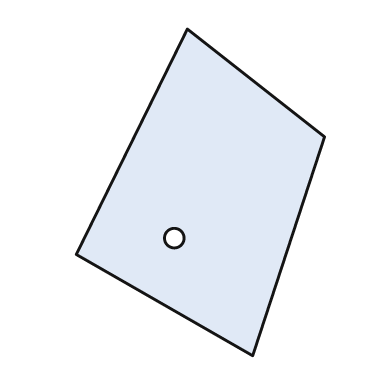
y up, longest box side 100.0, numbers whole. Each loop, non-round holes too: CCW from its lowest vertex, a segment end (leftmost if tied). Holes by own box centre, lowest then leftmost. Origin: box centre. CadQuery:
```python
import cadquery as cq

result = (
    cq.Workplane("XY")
    .moveTo(16.0, -50.0)
    .lineTo(38.0, 17.0)
    .lineTo(-4.0, 50.0)
    .lineTo(-38.0, -19.0)
    .close()
    .moveTo(-8.0, -14.0)
    .circle(3.0)
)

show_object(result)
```